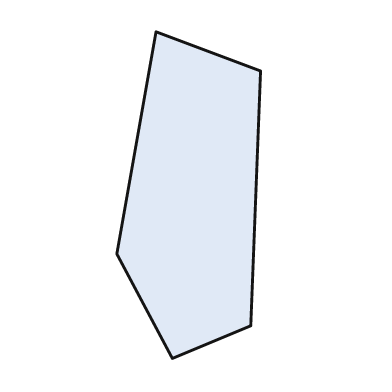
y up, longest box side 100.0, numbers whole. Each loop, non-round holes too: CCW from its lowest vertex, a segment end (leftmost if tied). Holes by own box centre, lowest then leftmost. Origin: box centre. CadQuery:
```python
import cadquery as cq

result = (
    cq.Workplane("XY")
    .moveTo(-5.0, -50.0)
    .lineTo(19.0, -40.0)
    .lineTo(22.0, 38.0)
    .lineTo(-10.0, 50.0)
    .lineTo(-22.0, -18.0)
    .close()
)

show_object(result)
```